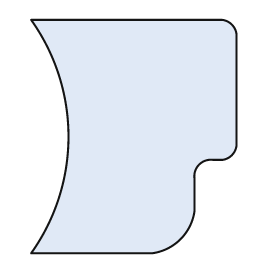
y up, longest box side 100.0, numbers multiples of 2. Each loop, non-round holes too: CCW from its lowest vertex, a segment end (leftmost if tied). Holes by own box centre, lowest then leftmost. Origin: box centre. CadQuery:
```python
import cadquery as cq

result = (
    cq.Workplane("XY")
    .moveTo(-44.0, -50.0)
    .lineTo(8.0, -50.0)
    .threePointArc((20.0, -44.0), (26.0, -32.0))
    .lineTo(26.0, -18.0)
    .threePointArc((28.0, -12.0), (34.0, -10.0))
    .lineTo(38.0, -10.0)
    .threePointArc((42.0, -8.0), (44.0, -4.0))
    .lineTo(44.0, 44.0)
    .threePointArc((42.0, 48.0), (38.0, 50.0))
    .lineTo(-44.0, 50.0)
    .threePointArc((-28.0, 0.0), (-44.0, -50.0))
    .close()
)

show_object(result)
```